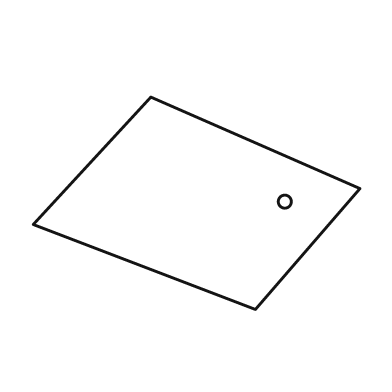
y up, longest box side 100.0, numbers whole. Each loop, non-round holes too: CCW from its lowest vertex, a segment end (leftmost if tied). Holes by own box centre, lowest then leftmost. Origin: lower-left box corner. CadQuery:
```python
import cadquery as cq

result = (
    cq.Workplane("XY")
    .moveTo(68.0, 0.0)
    .lineTo(100.0, 37.0)
    .lineTo(36.0, 65.0)
    .lineTo(0.0, 26.0)
    .close()
    .moveTo(77.0, 33.0)
    .circle(2.0)
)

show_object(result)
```